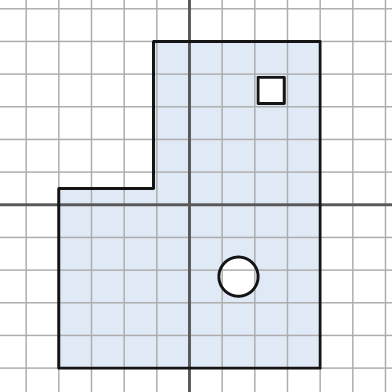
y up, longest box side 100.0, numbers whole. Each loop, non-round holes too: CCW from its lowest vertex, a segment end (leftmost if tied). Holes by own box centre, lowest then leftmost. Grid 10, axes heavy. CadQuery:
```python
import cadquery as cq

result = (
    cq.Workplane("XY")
    .moveTo(-40.0, -50.0)
    .lineTo(40.0, -50.0)
    .lineTo(40.0, 50.0)
    .lineTo(-11.0, 50.0)
    .lineTo(-11.0, 5.0)
    .lineTo(-40.0, 5.0)
    .close()
    .moveTo(15.0, -22.0)
    .circle(6.0)
    .moveTo(21.0, 31.0)
    .lineTo(29.0, 31.0)
    .lineTo(29.0, 39.0)
    .lineTo(21.0, 39.0)
    .close()
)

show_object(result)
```